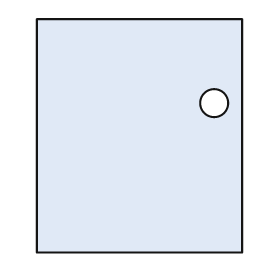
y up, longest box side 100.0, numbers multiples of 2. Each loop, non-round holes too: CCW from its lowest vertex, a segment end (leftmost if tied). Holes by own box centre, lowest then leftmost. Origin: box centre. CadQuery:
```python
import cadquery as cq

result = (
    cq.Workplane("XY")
    .moveTo(-44.0, -50.0)
    .lineTo(44.0, -50.0)
    .lineTo(44.0, 50.0)
    .lineTo(-44.0, 50.0)
    .close()
    .moveTo(32.0, 14.0)
    .circle(6.0)
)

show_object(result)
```